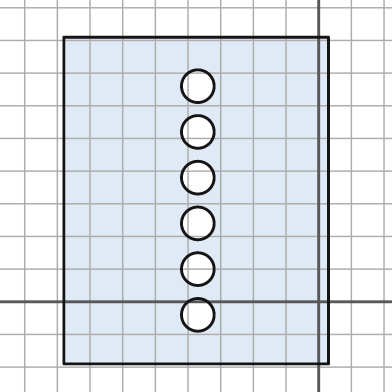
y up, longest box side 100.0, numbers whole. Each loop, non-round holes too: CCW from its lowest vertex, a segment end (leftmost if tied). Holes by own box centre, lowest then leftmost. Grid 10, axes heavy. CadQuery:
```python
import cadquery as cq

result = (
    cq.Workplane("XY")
    .moveTo(-78.0, -19.0)
    .lineTo(3.0, -19.0)
    .lineTo(3.0, 81.0)
    .lineTo(-78.0, 81.0)
    .close()
    .moveTo(-37.0, -4.0)
    .circle(5.0)
    .moveTo(-37.0, 10.0)
    .circle(5.0)
    .moveTo(-37.0, 24.0)
    .circle(5.0)
    .moveTo(-37.0, 38.0)
    .circle(5.0)
    .moveTo(-37.0, 52.0)
    .circle(5.0)
    .moveTo(-37.0, 66.0)
    .circle(5.0)
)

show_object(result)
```